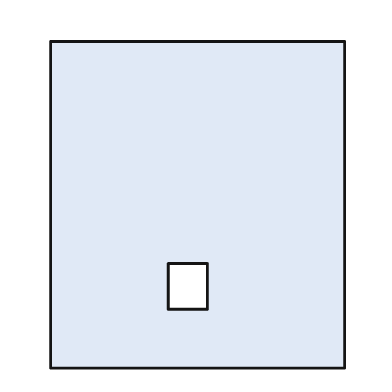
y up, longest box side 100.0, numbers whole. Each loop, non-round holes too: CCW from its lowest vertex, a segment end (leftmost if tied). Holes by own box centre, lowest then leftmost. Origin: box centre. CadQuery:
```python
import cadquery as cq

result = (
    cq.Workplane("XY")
    .moveTo(-45.0, -50.0)
    .lineTo(45.0, -50.0)
    .lineTo(45.0, 50.0)
    .lineTo(-45.0, 50.0)
    .close()
    .moveTo(-9.0, -32.0)
    .lineTo(3.0, -32.0)
    .lineTo(3.0, -18.0)
    .lineTo(-9.0, -18.0)
    .close()
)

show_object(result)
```